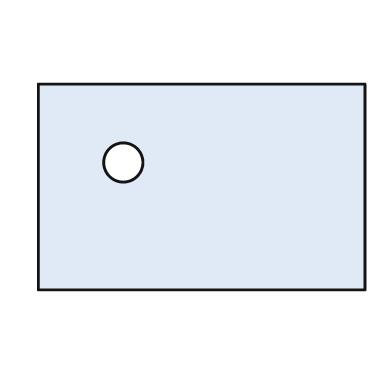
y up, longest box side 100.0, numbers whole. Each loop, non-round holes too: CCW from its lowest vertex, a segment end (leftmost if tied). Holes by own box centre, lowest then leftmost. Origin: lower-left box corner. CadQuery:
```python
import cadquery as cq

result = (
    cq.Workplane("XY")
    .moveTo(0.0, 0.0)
    .lineTo(100.0, 0.0)
    .lineTo(100.0, 63.0)
    .lineTo(0.0, 63.0)
    .close()
    .moveTo(26.0, 39.0)
    .circle(6.0)
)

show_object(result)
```